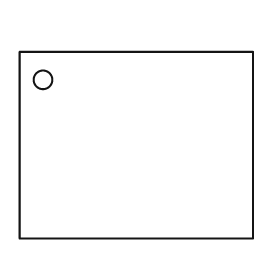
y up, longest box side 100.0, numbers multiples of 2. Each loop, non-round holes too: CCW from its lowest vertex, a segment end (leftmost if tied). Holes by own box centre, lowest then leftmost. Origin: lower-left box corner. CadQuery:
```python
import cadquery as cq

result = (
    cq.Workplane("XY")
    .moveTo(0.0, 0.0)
    .lineTo(100.0, 0.0)
    .lineTo(100.0, 80.0)
    .lineTo(0.0, 80.0)
    .close()
    .moveTo(10.0, 68.0)
    .circle(4.0)
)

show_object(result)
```